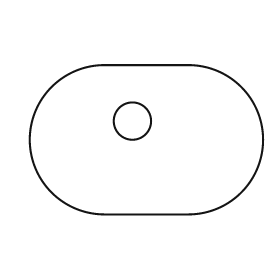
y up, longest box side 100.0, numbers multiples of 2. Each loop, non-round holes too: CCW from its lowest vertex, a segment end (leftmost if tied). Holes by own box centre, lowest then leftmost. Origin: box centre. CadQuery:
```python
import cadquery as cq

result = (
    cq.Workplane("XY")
    .moveTo(-18.0, -32.0)
    .lineTo(18.0, -32.0)
    .threePointArc((50.0, 0.0), (18.0, 32.0))
    .lineTo(-18.0, 32.0)
    .threePointArc((-50.0, 0.0), (-18.0, -32.0))
    .close()
    .moveTo(-6.0, 8.0)
    .circle(8.0)
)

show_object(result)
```